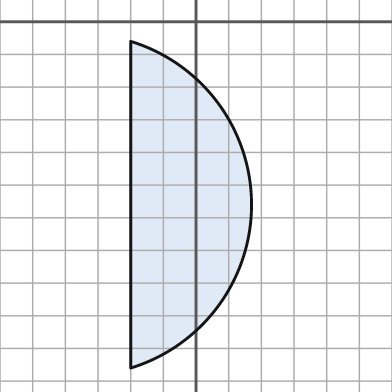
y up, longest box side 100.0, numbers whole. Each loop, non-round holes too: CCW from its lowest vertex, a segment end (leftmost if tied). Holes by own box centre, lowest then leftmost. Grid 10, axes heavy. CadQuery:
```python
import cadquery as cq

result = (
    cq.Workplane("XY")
    .moveTo(-20.0, -106.0)
    .threePointArc((17.0, -56.0), (-20.0, -6.0))
    .close()
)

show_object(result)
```